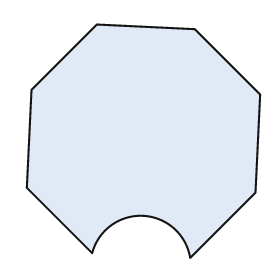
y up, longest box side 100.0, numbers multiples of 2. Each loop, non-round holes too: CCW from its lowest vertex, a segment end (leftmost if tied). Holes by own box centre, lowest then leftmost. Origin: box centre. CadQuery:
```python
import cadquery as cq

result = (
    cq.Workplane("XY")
    .moveTo(20.0, -50.0)
    .lineTo(48.0, -22.0)
    .lineTo(50.0, 20.0)
    .lineTo(22.0, 48.0)
    .lineTo(-20.0, 50.0)
    .lineTo(-48.0, 22.0)
    .lineTo(-50.0, -20.0)
    .lineTo(-22.0, -48.0)
    .threePointArc((0.0, -32.0), (20.0, -50.0))
    .close()
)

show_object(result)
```